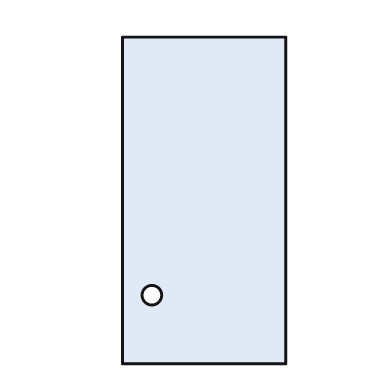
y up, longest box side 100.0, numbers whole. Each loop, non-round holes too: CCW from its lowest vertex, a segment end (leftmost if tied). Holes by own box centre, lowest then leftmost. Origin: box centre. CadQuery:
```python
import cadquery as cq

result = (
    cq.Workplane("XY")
    .moveTo(-25.0, -50.0)
    .lineTo(25.0, -50.0)
    .lineTo(25.0, 50.0)
    .lineTo(-25.0, 50.0)
    .close()
    .moveTo(-16.0, -29.0)
    .circle(3.0)
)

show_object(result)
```